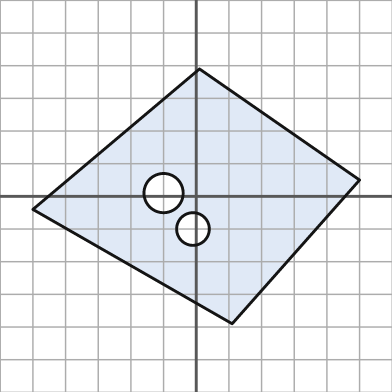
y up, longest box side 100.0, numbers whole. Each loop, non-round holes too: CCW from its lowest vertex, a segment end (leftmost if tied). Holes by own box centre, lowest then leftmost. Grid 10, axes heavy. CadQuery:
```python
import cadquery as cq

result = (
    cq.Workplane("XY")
    .moveTo(11.0, -39.0)
    .lineTo(50.0, 5.0)
    .lineTo(1.0, 39.0)
    .lineTo(-50.0, -4.0)
    .close()
    .moveTo(-1.0, -10.0)
    .circle(5.0)
    .moveTo(-10.0, 1.0)
    .circle(6.0)
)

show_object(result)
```